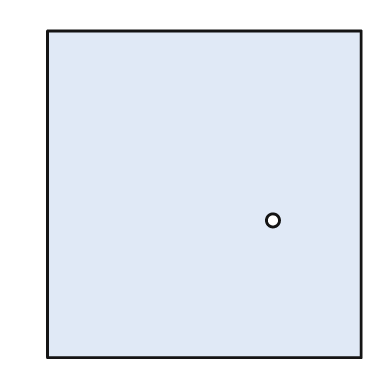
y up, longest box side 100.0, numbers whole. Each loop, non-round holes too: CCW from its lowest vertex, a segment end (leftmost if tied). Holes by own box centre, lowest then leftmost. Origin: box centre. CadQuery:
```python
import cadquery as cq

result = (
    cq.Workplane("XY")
    .moveTo(-48.0, -50.0)
    .lineTo(48.0, -50.0)
    .lineTo(48.0, 50.0)
    .lineTo(-48.0, 50.0)
    .close()
    .moveTo(21.0, -8.0)
    .circle(2.0)
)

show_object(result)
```